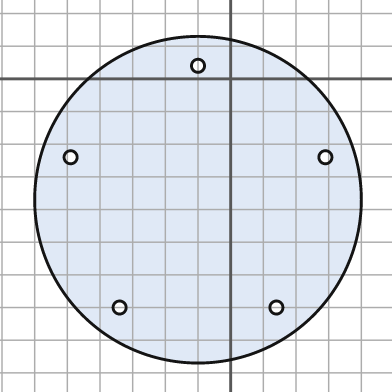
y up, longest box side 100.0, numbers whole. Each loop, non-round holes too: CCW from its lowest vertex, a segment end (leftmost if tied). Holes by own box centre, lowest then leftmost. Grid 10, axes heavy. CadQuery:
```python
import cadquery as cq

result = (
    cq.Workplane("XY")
    .moveTo(-10.0, -37.0)
    .circle(50.0)
    .moveTo(-34.0, -70.0)
    .circle(2.0)
    .moveTo(14.0, -70.0)
    .circle(2.0)
    .moveTo(-49.0, -24.0)
    .circle(2.0)
    .moveTo(29.0, -24.0)
    .circle(2.0)
    .moveTo(-10.0, 4.0)
    .circle(2.0)
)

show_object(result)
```